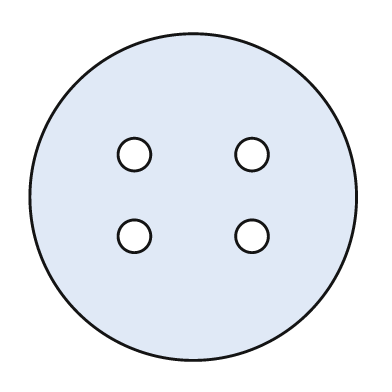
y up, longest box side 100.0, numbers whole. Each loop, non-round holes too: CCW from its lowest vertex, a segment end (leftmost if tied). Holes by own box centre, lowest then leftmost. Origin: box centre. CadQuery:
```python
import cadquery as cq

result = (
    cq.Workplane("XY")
    .moveTo(0.0, 0.0)
    .circle(50.0)
    .moveTo(-18.0, -12.0)
    .circle(5.0)
    .moveTo(18.0, -12.0)
    .circle(5.0)
    .moveTo(-18.0, 13.0)
    .circle(5.0)
    .moveTo(18.0, 13.0)
    .circle(5.0)
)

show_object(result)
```